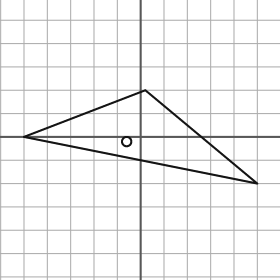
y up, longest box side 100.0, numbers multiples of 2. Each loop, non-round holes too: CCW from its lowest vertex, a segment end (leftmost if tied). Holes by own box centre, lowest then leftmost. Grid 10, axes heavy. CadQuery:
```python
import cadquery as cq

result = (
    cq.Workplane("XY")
    .moveTo(50.0, -20.0)
    .lineTo(2.0, 20.0)
    .lineTo(-50.0, 0.0)
    .close()
    .moveTo(-6.0, -2.0)
    .circle(2.0)
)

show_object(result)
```